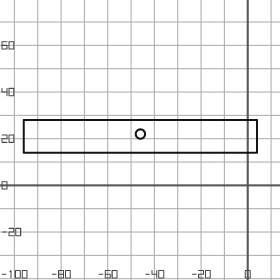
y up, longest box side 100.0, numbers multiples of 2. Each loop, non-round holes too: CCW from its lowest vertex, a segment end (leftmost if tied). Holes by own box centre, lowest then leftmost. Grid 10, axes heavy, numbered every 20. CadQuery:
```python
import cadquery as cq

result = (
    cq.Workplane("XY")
    .moveTo(-96.0, 14.0)
    .lineTo(4.0, 14.0)
    .lineTo(4.0, 28.0)
    .lineTo(-96.0, 28.0)
    .close()
    .moveTo(-46.0, 22.0)
    .circle(2.0)
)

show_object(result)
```